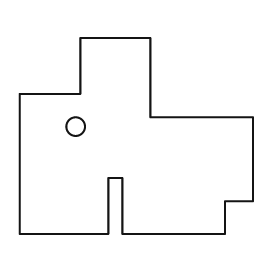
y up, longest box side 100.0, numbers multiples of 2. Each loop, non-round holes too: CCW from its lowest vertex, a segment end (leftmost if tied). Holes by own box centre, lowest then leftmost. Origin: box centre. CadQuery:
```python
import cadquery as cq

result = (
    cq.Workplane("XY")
    .moveTo(-50.0, -42.0)
    .lineTo(-12.0, -42.0)
    .lineTo(-12.0, -18.0)
    .lineTo(-6.0, -18.0)
    .lineTo(-6.0, -42.0)
    .lineTo(38.0, -42.0)
    .lineTo(38.0, -28.0)
    .lineTo(50.0, -28.0)
    .lineTo(50.0, 8.0)
    .lineTo(6.0, 8.0)
    .lineTo(6.0, 42.0)
    .lineTo(-24.0, 42.0)
    .lineTo(-24.0, 18.0)
    .lineTo(-50.0, 18.0)
    .close()
    .moveTo(-26.0, 4.0)
    .circle(4.0)
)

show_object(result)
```